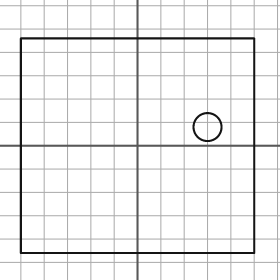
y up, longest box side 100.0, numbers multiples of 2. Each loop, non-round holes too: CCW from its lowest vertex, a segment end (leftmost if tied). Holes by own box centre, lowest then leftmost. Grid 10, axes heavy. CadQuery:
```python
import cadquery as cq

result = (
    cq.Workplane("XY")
    .moveTo(-50.0, -46.0)
    .lineTo(50.0, -46.0)
    .lineTo(50.0, 46.0)
    .lineTo(-50.0, 46.0)
    .close()
    .moveTo(30.0, 8.0)
    .circle(6.0)
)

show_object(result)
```